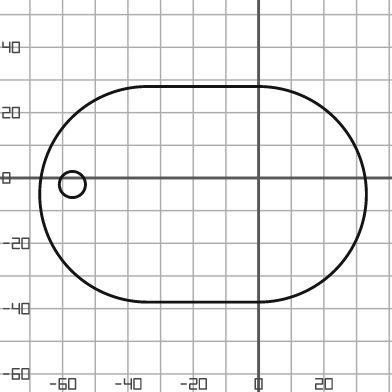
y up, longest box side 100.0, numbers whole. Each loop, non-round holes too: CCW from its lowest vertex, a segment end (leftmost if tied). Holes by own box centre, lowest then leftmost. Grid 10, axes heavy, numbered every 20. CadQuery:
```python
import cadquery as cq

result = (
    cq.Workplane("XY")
    .moveTo(-34.0, -38.0)
    .lineTo(0.0, -38.0)
    .threePointArc((33.0, -5.0), (0.0, 28.0))
    .lineTo(-34.0, 28.0)
    .threePointArc((-67.0, -5.0), (-34.0, -38.0))
    .close()
    .moveTo(-57.0, -2.0)
    .circle(4.0)
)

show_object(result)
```